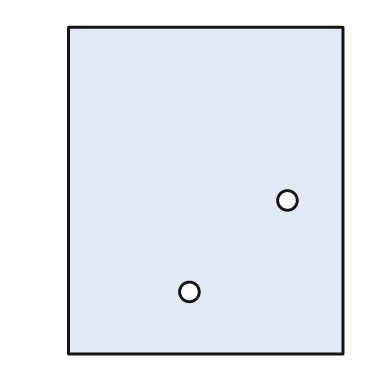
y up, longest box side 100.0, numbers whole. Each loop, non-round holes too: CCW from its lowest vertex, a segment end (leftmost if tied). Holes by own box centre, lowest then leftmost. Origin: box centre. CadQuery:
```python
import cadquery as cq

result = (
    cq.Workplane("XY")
    .moveTo(-42.0, -50.0)
    .lineTo(42.0, -50.0)
    .lineTo(42.0, 50.0)
    .lineTo(-42.0, 50.0)
    .close()
    .moveTo(-5.0, -31.0)
    .circle(3.0)
    .moveTo(25.0, -3.0)
    .circle(3.0)
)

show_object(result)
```